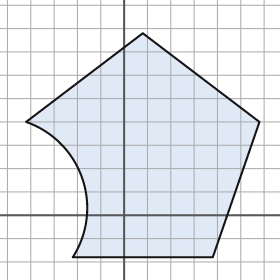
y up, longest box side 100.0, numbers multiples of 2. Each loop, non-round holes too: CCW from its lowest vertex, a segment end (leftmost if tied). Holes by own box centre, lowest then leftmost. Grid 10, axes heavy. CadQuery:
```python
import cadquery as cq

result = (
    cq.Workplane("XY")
    .moveTo(-22.0, -18.0)
    .lineTo(38.0, -18.0)
    .lineTo(58.0, 40.0)
    .lineTo(8.0, 78.0)
    .lineTo(-42.0, 40.0)
    .threePointArc((-18.0, 16.0), (-22.0, -18.0))
    .close()
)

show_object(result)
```